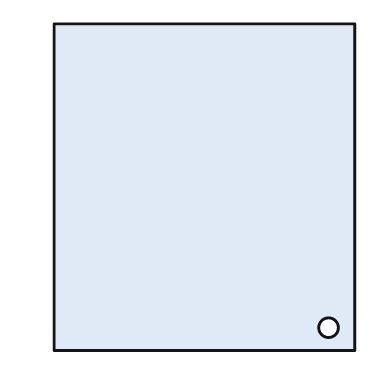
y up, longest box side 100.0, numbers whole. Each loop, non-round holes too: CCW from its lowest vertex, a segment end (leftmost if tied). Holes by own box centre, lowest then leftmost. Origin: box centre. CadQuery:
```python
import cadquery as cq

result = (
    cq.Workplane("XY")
    .moveTo(-46.0, -50.0)
    .lineTo(46.0, -50.0)
    .lineTo(46.0, 50.0)
    .lineTo(-46.0, 50.0)
    .close()
    .moveTo(38.0, -43.0)
    .circle(3.0)
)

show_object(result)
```